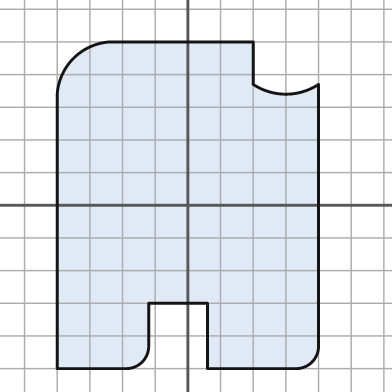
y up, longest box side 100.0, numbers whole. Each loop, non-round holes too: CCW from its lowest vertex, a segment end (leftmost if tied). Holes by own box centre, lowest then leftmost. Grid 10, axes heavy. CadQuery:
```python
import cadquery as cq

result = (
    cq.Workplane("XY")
    .moveTo(-40.0, -50.0)
    .lineTo(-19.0, -50.0)
    .threePointArc((-14.0, -48.0), (-12.0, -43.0))
    .lineTo(-12.0, -30.0)
    .lineTo(6.0, -30.0)
    .lineTo(6.0, -50.0)
    .lineTo(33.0, -50.0)
    .threePointArc((38.0, -48.0), (40.0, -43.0))
    .lineTo(40.0, 37.0)
    .threePointArc((30.0, 34.0), (20.0, 37.0))
    .lineTo(20.0, 50.0)
    .lineTo(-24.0, 50.0)
    .threePointArc((-35.0, 45.0), (-40.0, 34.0))
    .close()
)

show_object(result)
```